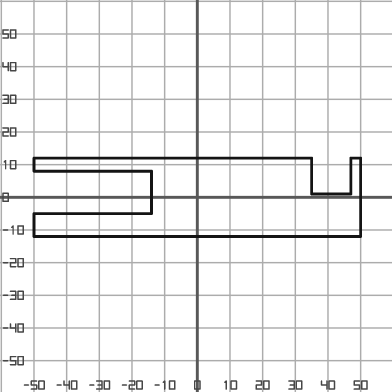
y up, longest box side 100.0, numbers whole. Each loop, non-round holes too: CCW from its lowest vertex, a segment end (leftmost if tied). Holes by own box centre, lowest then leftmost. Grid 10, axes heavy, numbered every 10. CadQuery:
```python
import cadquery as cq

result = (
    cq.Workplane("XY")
    .moveTo(-50.0, -12.0)
    .lineTo(50.0, -12.0)
    .lineTo(50.0, 12.0)
    .lineTo(47.0, 12.0)
    .lineTo(47.0, 1.0)
    .lineTo(35.0, 1.0)
    .lineTo(35.0, 12.0)
    .lineTo(-50.0, 12.0)
    .lineTo(-50.0, 8.0)
    .lineTo(-14.0, 8.0)
    .lineTo(-14.0, -5.0)
    .lineTo(-50.0, -5.0)
    .close()
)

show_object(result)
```